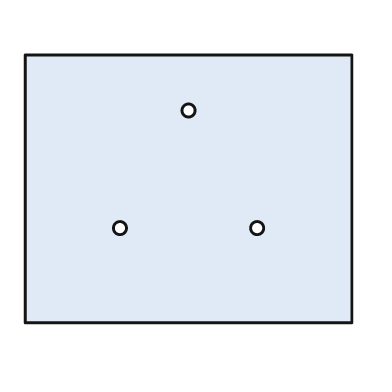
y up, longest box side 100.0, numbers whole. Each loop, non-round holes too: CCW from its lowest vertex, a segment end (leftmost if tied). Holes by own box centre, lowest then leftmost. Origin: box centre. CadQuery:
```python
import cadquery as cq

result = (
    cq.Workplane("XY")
    .moveTo(-50.0, -41.0)
    .lineTo(50.0, -41.0)
    .lineTo(50.0, 41.0)
    .lineTo(-50.0, 41.0)
    .close()
    .moveTo(-21.0, -12.0)
    .circle(2.0)
    .moveTo(21.0, -12.0)
    .circle(2.0)
    .moveTo(0.0, 24.0)
    .circle(2.0)
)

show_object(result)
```